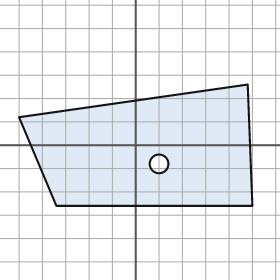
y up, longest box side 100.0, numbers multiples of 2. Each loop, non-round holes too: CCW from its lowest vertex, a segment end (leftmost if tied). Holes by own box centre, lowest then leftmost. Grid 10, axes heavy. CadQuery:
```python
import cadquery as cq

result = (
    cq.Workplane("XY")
    .moveTo(-34.0, -26.0)
    .lineTo(50.0, -26.0)
    .lineTo(48.0, 26.0)
    .lineTo(-50.0, 12.0)
    .close()
    .moveTo(10.0, -8.0)
    .circle(4.0)
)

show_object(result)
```